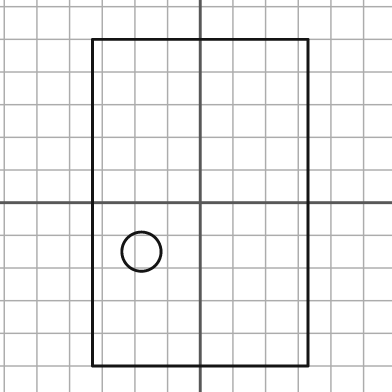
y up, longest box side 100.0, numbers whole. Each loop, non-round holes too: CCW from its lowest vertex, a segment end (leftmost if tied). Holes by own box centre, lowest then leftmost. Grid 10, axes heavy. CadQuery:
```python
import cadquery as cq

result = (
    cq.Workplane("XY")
    .moveTo(-33.0, -50.0)
    .lineTo(33.0, -50.0)
    .lineTo(33.0, 50.0)
    .lineTo(-33.0, 50.0)
    .close()
    .moveTo(-18.0, -15.0)
    .circle(6.0)
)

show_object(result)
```